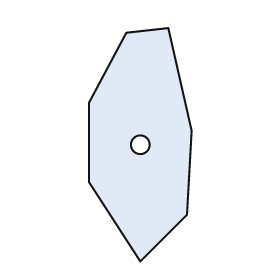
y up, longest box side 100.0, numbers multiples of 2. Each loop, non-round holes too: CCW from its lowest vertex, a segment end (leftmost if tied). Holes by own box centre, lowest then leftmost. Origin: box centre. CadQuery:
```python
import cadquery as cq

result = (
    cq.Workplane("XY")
    .moveTo(0.0, -50.0)
    .lineTo(20.0, -30.0)
    .lineTo(22.0, 6.0)
    .lineTo(12.0, 50.0)
    .lineTo(-6.0, 48.0)
    .lineTo(-22.0, 18.0)
    .lineTo(-22.0, -16.0)
    .close()
    .moveTo(0.0, 0.0)
    .circle(4.0)
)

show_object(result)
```